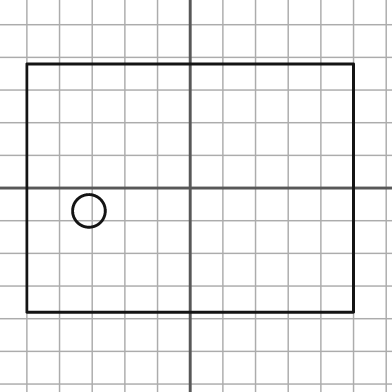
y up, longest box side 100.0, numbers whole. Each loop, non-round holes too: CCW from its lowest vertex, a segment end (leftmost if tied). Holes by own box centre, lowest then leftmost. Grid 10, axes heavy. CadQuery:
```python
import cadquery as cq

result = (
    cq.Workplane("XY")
    .moveTo(-50.0, -38.0)
    .lineTo(50.0, -38.0)
    .lineTo(50.0, 38.0)
    .lineTo(-50.0, 38.0)
    .close()
    .moveTo(-31.0, -7.0)
    .circle(5.0)
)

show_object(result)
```